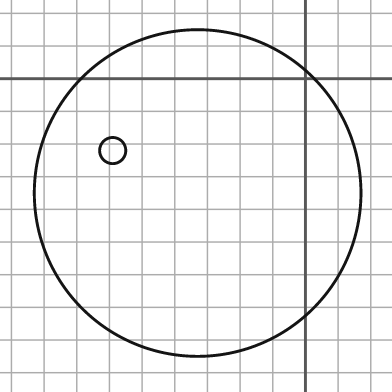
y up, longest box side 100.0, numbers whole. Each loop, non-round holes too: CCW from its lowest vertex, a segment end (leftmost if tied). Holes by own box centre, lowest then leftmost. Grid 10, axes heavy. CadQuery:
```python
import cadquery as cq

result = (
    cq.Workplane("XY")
    .moveTo(-33.0, -35.0)
    .circle(50.0)
    .moveTo(-59.0, -22.0)
    .circle(4.0)
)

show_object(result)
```